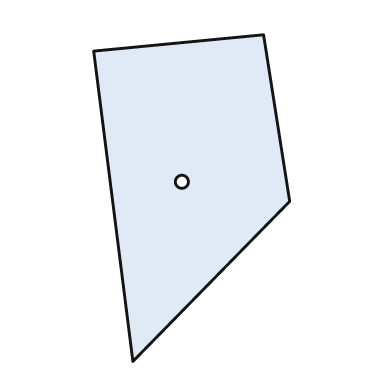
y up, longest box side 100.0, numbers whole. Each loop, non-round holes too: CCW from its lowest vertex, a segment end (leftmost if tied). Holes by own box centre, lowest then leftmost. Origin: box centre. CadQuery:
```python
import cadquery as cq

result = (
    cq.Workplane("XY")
    .moveTo(-18.0, -50.0)
    .lineTo(30.0, -1.0)
    .lineTo(22.0, 50.0)
    .lineTo(-30.0, 45.0)
    .close()
    .moveTo(-3.0, 5.0)
    .circle(2.0)
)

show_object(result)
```